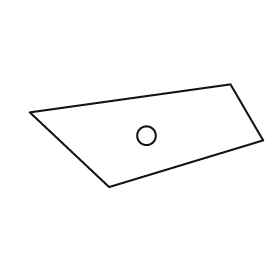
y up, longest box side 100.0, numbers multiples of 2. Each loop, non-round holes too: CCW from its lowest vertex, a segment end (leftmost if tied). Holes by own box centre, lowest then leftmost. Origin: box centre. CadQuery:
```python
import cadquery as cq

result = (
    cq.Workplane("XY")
    .moveTo(-16.0, -22.0)
    .lineTo(50.0, -2.0)
    .lineTo(36.0, 22.0)
    .lineTo(-50.0, 10.0)
    .close()
    .moveTo(0.0, 0.0)
    .circle(4.0)
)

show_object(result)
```